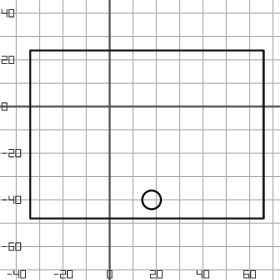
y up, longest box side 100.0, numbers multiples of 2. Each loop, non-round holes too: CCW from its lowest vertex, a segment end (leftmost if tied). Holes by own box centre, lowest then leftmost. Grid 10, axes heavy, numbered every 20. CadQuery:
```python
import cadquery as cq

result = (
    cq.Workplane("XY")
    .moveTo(-34.0, -48.0)
    .lineTo(66.0, -48.0)
    .lineTo(66.0, 24.0)
    .lineTo(-34.0, 24.0)
    .close()
    .moveTo(18.0, -40.0)
    .circle(4.0)
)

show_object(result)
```